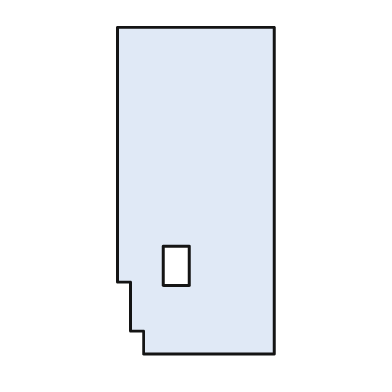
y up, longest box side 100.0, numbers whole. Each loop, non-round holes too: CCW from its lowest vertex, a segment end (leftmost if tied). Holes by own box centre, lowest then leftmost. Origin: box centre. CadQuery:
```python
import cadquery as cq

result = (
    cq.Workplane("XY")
    .moveTo(-16.0, -50.0)
    .lineTo(24.0, -50.0)
    .lineTo(24.0, 50.0)
    .lineTo(-24.0, 50.0)
    .lineTo(-24.0, -28.0)
    .lineTo(-20.0, -28.0)
    .lineTo(-20.0, -43.0)
    .lineTo(-16.0, -43.0)
    .close()
    .moveTo(-10.0, -29.0)
    .lineTo(-2.0, -29.0)
    .lineTo(-2.0, -17.0)
    .lineTo(-10.0, -17.0)
    .close()
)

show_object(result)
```